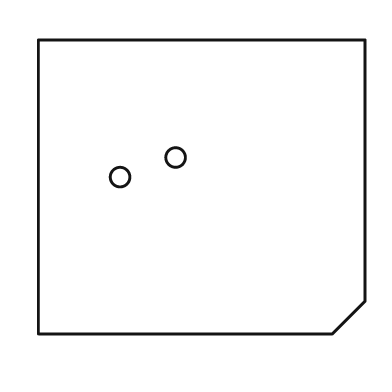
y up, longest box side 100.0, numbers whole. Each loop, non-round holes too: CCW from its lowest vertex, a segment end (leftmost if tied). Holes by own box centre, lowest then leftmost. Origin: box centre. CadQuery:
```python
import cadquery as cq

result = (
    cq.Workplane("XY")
    .moveTo(-50.0, -45.0)
    .lineTo(40.0, -45.0)
    .lineTo(50.0, -35.0)
    .lineTo(50.0, 45.0)
    .lineTo(-50.0, 45.0)
    .close()
    .moveTo(-25.0, 3.0)
    .circle(3.0)
    .moveTo(-8.0, 9.0)
    .circle(3.0)
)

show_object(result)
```